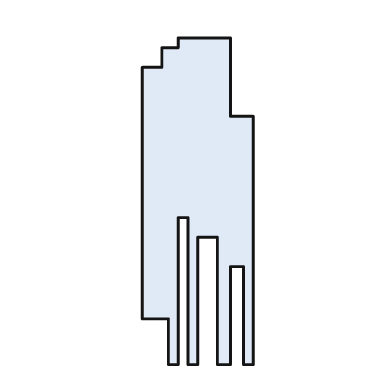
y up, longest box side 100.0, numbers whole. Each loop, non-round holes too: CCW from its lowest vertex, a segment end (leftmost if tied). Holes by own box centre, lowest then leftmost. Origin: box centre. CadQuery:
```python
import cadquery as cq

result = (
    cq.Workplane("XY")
    .moveTo(-9.0, -50.0)
    .lineTo(-6.0, -50.0)
    .lineTo(-6.0, -5.0)
    .lineTo(-3.0, -5.0)
    .lineTo(-3.0, -50.0)
    .lineTo(0.0, -50.0)
    .lineTo(0.0, -11.0)
    .lineTo(6.0, -11.0)
    .lineTo(6.0, -50.0)
    .lineTo(10.0, -50.0)
    .lineTo(10.0, -20.0)
    .lineTo(14.0, -20.0)
    .lineTo(14.0, -50.0)
    .lineTo(17.0, -50.0)
    .lineTo(17.0, 26.0)
    .lineTo(10.0, 26.0)
    .lineTo(10.0, 50.0)
    .lineTo(-6.0, 50.0)
    .lineTo(-6.0, 47.0)
    .lineTo(-11.0, 47.0)
    .lineTo(-11.0, 41.0)
    .lineTo(-17.0, 41.0)
    .lineTo(-17.0, -36.0)
    .lineTo(-9.0, -36.0)
    .close()
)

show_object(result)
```